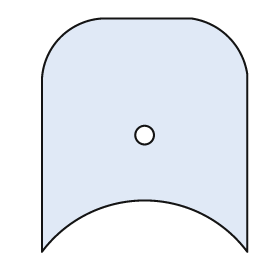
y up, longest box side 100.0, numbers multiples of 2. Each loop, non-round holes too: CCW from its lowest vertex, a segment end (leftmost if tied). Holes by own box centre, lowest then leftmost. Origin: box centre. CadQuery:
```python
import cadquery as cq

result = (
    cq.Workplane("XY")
    .moveTo(-44.0, -50.0)
    .threePointArc((0.0, -28.0), (44.0, -50.0))
    .lineTo(44.0, 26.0)
    .threePointArc((36.0, 42.0), (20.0, 50.0))
    .lineTo(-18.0, 50.0)
    .threePointArc((-36.0, 42.0), (-44.0, 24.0))
    .close()
    .moveTo(0.0, 0.0)
    .circle(4.0)
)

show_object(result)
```